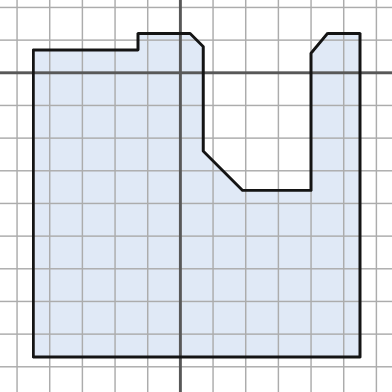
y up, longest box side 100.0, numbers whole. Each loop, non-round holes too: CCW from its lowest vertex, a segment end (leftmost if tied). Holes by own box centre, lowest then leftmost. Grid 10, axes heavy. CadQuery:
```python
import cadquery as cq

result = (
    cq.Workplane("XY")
    .moveTo(-45.0, -87.0)
    .lineTo(55.0, -87.0)
    .lineTo(55.0, 12.0)
    .lineTo(45.0, 12.0)
    .lineTo(40.0, 6.0)
    .lineTo(40.0, -36.0)
    .lineTo(19.0, -36.0)
    .lineTo(7.0, -24.0)
    .lineTo(7.0, 8.0)
    .lineTo(3.0, 12.0)
    .lineTo(-13.0, 12.0)
    .lineTo(-13.0, 7.0)
    .lineTo(-45.0, 7.0)
    .close()
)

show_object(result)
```